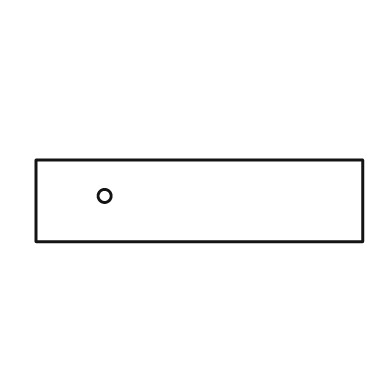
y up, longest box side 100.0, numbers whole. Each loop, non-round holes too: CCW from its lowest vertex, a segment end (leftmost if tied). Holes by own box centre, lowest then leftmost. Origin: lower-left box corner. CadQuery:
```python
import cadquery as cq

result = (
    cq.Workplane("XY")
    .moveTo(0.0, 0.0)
    .lineTo(100.0, 0.0)
    .lineTo(100.0, 25.0)
    .lineTo(0.0, 25.0)
    .close()
    .moveTo(21.0, 14.0)
    .circle(2.0)
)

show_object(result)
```